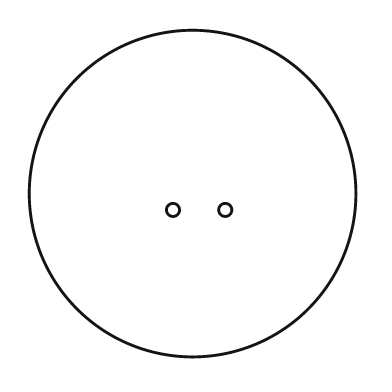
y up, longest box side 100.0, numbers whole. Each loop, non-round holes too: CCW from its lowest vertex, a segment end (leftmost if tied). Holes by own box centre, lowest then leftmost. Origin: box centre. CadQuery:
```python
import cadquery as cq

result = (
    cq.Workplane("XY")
    .moveTo(0.0, 0.0)
    .circle(50.0)
    .moveTo(-6.0, -5.0)
    .circle(2.0)
    .moveTo(10.0, -5.0)
    .circle(2.0)
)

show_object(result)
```